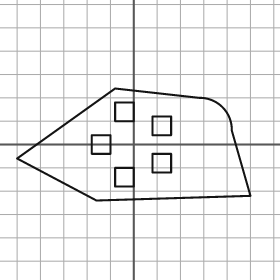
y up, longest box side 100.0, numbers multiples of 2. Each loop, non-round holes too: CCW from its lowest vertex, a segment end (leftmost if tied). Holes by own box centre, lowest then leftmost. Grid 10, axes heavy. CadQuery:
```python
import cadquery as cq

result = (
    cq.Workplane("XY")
    .moveTo(-16.0, -24.0)
    .lineTo(50.0, -22.0)
    .lineTo(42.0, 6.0)
    .threePointArc((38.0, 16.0), (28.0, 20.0))
    .lineTo(-8.0, 24.0)
    .lineTo(-50.0, -6.0)
    .close()
    .moveTo(-8.0, -18.0)
    .lineTo(0.0, -18.0)
    .lineTo(0.0, -10.0)
    .lineTo(-8.0, -10.0)
    .close()
    .moveTo(8.0, -12.0)
    .lineTo(16.0, -12.0)
    .lineTo(16.0, -4.0)
    .lineTo(8.0, -4.0)
    .close()
    .moveTo(-18.0, -4.0)
    .lineTo(-10.0, -4.0)
    .lineTo(-10.0, 4.0)
    .lineTo(-18.0, 4.0)
    .close()
    .moveTo(8.0, 4.0)
    .lineTo(16.0, 4.0)
    .lineTo(16.0, 12.0)
    .lineTo(8.0, 12.0)
    .close()
    .moveTo(-8.0, 10.0)
    .lineTo(0.0, 10.0)
    .lineTo(0.0, 18.0)
    .lineTo(-8.0, 18.0)
    .close()
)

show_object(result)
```